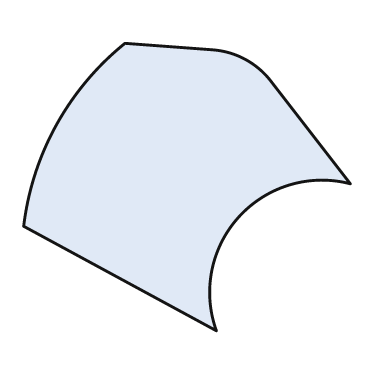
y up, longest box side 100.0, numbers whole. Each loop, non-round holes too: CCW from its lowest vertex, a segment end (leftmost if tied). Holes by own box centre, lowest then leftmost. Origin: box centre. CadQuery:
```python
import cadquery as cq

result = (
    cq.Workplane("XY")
    .moveTo(9.0, -44.0)
    .threePointArc((16.0, -9.0), (50.0, 1.0))
    .lineTo(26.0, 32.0)
    .threePointArc((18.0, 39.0), (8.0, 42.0))
    .lineTo(-19.0, 44.0)
    .threePointArc((-40.0, 19.0), (-50.0, -12.0))
    .close()
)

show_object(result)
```